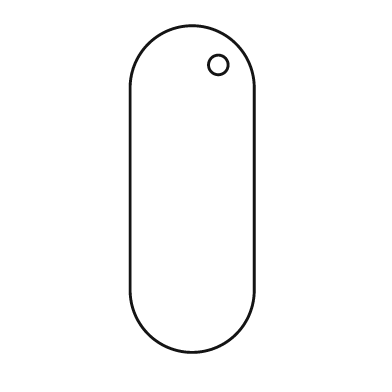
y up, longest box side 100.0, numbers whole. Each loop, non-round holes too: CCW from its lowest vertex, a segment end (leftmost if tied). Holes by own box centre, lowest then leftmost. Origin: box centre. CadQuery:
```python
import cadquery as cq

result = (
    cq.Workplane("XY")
    .moveTo(-19.0, -31.0)
    .threePointArc((0.0, -50.0), (19.0, -31.0))
    .lineTo(19.0, 31.0)
    .threePointArc((0.0, 50.0), (-19.0, 31.0))
    .close()
    .moveTo(8.0, 38.0)
    .circle(3.0)
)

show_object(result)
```